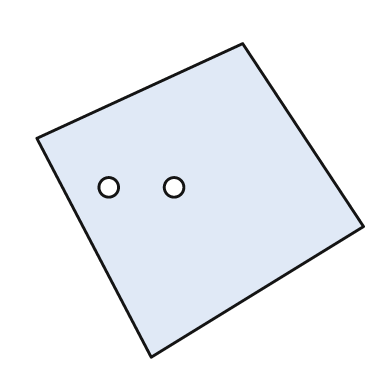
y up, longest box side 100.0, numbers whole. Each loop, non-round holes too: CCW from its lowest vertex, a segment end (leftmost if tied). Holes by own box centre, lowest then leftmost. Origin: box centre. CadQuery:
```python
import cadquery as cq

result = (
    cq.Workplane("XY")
    .moveTo(-15.0, -48.0)
    .lineTo(50.0, -8.0)
    .lineTo(13.0, 48.0)
    .lineTo(-50.0, 19.0)
    .close()
    .moveTo(-28.0, 4.0)
    .circle(3.0)
    .moveTo(-8.0, 4.0)
    .circle(3.0)
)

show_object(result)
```